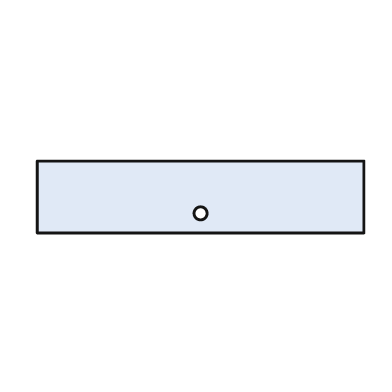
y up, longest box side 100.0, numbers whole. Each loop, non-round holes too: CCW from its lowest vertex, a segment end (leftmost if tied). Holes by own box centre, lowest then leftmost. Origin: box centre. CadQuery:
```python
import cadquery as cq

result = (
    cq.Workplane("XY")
    .moveTo(-50.0, -11.0)
    .lineTo(50.0, -11.0)
    .lineTo(50.0, 11.0)
    .lineTo(-50.0, 11.0)
    .close()
    .moveTo(0.0, -5.0)
    .circle(2.0)
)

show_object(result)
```